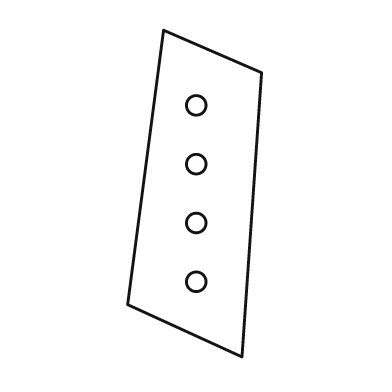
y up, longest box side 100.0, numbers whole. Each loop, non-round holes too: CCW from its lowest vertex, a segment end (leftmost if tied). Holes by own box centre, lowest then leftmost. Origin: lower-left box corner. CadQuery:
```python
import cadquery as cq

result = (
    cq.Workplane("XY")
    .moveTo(35.0, 0.0)
    .lineTo(41.0, 87.0)
    .lineTo(11.0, 100.0)
    .lineTo(0.0, 16.0)
    .close()
    .moveTo(21.0, 23.0)
    .circle(3.0)
    .moveTo(21.0, 41.0)
    .circle(3.0)
    .moveTo(21.0, 59.0)
    .circle(3.0)
    .moveTo(21.0, 77.0)
    .circle(3.0)
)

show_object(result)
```